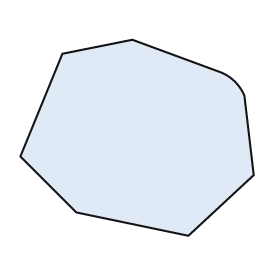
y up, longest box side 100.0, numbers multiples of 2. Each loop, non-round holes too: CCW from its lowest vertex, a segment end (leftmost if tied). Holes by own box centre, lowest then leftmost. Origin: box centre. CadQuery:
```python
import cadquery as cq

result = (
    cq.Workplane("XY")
    .moveTo(22.0, -42.0)
    .lineTo(50.0, -16.0)
    .lineTo(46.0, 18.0)
    .threePointArc((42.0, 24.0), (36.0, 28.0))
    .lineTo(-2.0, 42.0)
    .lineTo(-32.0, 36.0)
    .lineTo(-50.0, -8.0)
    .lineTo(-26.0, -32.0)
    .close()
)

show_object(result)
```